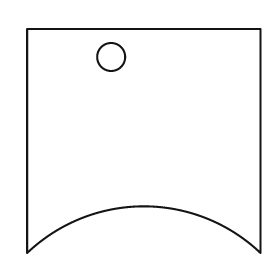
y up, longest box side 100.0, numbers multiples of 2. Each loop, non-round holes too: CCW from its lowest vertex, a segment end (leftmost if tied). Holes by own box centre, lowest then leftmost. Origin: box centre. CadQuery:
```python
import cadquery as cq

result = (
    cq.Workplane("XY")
    .moveTo(-50.0, -48.0)
    .threePointArc((0.0, -28.0), (50.0, -48.0))
    .lineTo(50.0, 48.0)
    .lineTo(-50.0, 48.0)
    .close()
    .moveTo(-14.0, 36.0)
    .circle(6.0)
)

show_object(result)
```